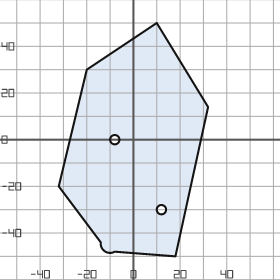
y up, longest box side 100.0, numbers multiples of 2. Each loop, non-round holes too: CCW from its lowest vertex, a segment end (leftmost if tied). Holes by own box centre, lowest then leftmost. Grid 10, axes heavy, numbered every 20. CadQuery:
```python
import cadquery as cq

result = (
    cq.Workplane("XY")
    .moveTo(18.0, -50.0)
    .lineTo(32.0, 14.0)
    .lineTo(10.0, 50.0)
    .lineTo(-20.0, 30.0)
    .lineTo(-32.0, -20.0)
    .lineTo(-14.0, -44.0)
    .threePointArc((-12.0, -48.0), (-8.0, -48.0))
    .close()
    .moveTo(12.0, -30.0)
    .circle(2.0)
    .moveTo(-8.0, 0.0)
    .circle(2.0)
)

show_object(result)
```